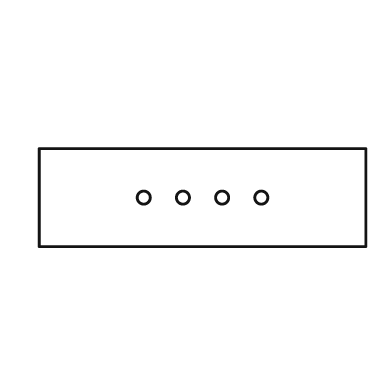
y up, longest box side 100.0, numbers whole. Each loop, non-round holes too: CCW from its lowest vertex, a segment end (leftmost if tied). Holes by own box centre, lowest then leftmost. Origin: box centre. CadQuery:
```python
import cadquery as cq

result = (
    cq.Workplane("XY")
    .moveTo(-50.0, -15.0)
    .lineTo(50.0, -15.0)
    .lineTo(50.0, 15.0)
    .lineTo(-50.0, 15.0)
    .close()
    .moveTo(-18.0, 0.0)
    .circle(2.0)
    .moveTo(-6.0, 0.0)
    .circle(2.0)
    .moveTo(6.0, 0.0)
    .circle(2.0)
    .moveTo(18.0, 0.0)
    .circle(2.0)
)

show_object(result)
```